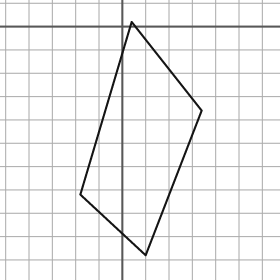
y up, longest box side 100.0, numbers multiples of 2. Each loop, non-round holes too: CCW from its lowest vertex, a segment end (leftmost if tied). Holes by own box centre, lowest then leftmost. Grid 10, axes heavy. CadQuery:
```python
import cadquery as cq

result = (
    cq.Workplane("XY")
    .moveTo(10.0, -98.0)
    .lineTo(34.0, -36.0)
    .lineTo(4.0, 2.0)
    .lineTo(-18.0, -72.0)
    .close()
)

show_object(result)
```